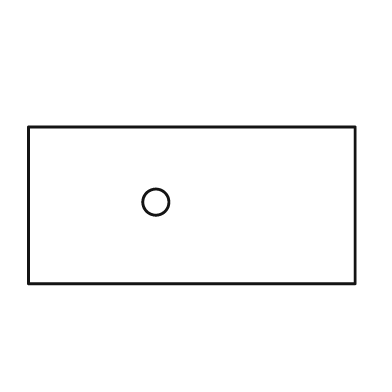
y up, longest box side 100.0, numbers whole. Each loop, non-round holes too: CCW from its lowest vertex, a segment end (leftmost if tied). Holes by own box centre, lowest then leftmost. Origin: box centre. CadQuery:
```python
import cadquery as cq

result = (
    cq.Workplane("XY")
    .moveTo(-50.0, -24.0)
    .lineTo(50.0, -24.0)
    .lineTo(50.0, 24.0)
    .lineTo(-50.0, 24.0)
    .close()
    .moveTo(-11.0, 1.0)
    .circle(4.0)
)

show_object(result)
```